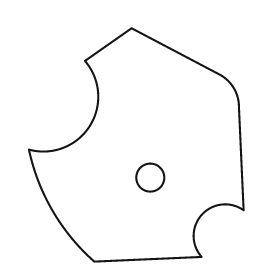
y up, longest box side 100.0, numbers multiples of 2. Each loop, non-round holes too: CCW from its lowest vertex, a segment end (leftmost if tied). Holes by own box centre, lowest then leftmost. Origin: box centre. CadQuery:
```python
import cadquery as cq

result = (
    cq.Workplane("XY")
    .moveTo(-18.0, -50.0)
    .lineTo(28.0, -48.0)
    .threePointArc((28.0, -30.0), (46.0, -28.0))
    .lineTo(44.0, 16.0)
    .threePointArc((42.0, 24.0), (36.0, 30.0))
    .lineTo(-2.0, 50.0)
    .lineTo(-22.0, 36.0)
    .threePointArc((-20.0, 8.0), (-46.0, -2.0))
    .threePointArc((-36.0, -28.0), (-18.0, -50.0))
    .close()
    .moveTo(6.0, -14.0)
    .circle(6.0)
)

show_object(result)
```